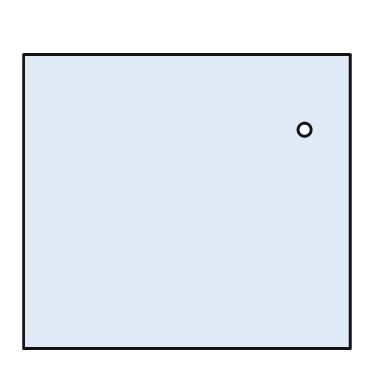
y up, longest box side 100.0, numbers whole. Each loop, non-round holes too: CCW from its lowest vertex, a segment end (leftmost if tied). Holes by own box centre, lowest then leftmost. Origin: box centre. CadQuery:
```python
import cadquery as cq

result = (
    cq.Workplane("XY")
    .moveTo(-50.0, -45.0)
    .lineTo(50.0, -45.0)
    .lineTo(50.0, 45.0)
    .lineTo(-50.0, 45.0)
    .close()
    .moveTo(36.0, 22.0)
    .circle(2.0)
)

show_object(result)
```